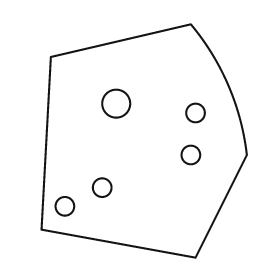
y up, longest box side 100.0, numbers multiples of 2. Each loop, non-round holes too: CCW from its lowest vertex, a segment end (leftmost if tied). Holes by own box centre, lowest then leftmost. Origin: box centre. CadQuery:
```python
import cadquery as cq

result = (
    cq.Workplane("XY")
    .moveTo(22.0, -50.0)
    .lineTo(44.0, -6.0)
    .threePointArc((36.0, 24.0), (20.0, 50.0))
    .lineTo(-40.0, 36.0)
    .lineTo(-44.0, -38.0)
    .close()
    .moveTo(-34.0, -28.0)
    .circle(4.0)
    .moveTo(-18.0, -20.0)
    .circle(4.0)
    .moveTo(20.0, -6.0)
    .circle(4.0)
    .moveTo(22.0, 12.0)
    .circle(4.0)
    .moveTo(-12.0, 16.0)
    .circle(6.0)
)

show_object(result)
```